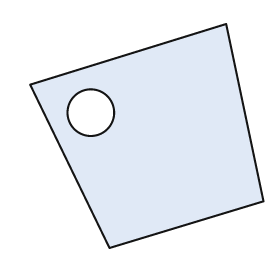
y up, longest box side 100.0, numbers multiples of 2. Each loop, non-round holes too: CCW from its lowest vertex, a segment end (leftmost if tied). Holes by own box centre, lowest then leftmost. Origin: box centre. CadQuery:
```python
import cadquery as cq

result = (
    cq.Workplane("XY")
    .moveTo(-16.0, -48.0)
    .lineTo(50.0, -28.0)
    .lineTo(34.0, 48.0)
    .lineTo(-50.0, 22.0)
    .close()
    .moveTo(-24.0, 10.0)
    .circle(10.0)
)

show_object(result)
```